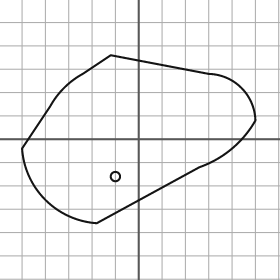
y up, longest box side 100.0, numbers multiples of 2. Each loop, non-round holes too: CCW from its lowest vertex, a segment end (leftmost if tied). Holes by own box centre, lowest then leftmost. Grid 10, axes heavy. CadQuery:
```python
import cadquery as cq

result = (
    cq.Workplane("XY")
    .moveTo(-18.0, -36.0)
    .lineTo(26.0, -12.0)
    .threePointArc((40.0, -4.0), (50.0, 8.0))
    .threePointArc((44.0, 22.0), (30.0, 28.0))
    .lineTo(-12.0, 36.0)
    .lineTo(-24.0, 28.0)
    .threePointArc((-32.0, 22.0), (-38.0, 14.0))
    .lineTo(-50.0, -4.0)
    .threePointArc((-40.0, -26.0), (-18.0, -36.0))
    .close()
    .moveTo(-10.0, -16.0)
    .circle(2.0)
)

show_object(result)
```